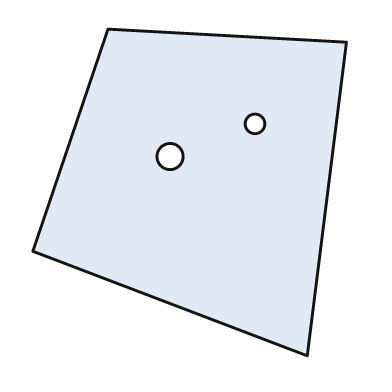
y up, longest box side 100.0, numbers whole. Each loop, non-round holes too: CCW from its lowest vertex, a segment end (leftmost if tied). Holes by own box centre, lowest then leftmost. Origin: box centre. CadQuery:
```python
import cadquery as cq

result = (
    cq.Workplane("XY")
    .moveTo(36.0, -50.0)
    .lineTo(48.0, 46.0)
    .lineTo(-25.0, 50.0)
    .lineTo(-48.0, -18.0)
    .close()
    .moveTo(-6.0, 11.0)
    .circle(4.0)
    .moveTo(20.0, 21.0)
    .circle(3.0)
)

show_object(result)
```